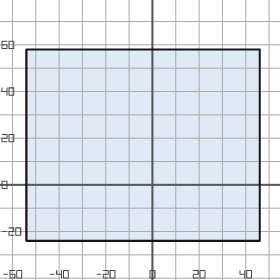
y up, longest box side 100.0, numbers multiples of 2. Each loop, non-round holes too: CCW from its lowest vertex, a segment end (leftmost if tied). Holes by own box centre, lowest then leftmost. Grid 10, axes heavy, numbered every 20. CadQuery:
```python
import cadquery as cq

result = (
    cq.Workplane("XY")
    .moveTo(-54.0, -24.0)
    .lineTo(46.0, -24.0)
    .lineTo(46.0, 58.0)
    .lineTo(-54.0, 58.0)
    .close()
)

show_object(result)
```